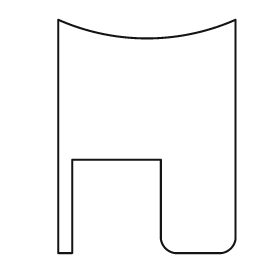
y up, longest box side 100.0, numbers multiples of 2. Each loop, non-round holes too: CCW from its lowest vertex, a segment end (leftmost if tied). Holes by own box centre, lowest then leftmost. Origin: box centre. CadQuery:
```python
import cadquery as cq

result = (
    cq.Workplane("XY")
    .moveTo(-38.0, -50.0)
    .lineTo(-32.0, -50.0)
    .lineTo(-32.0, -10.0)
    .lineTo(6.0, -10.0)
    .lineTo(6.0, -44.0)
    .threePointArc((8.0, -48.0), (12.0, -50.0))
    .lineTo(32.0, -50.0)
    .threePointArc((36.0, -48.0), (38.0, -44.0))
    .lineTo(38.0, 50.0)
    .threePointArc((0.0, 42.0), (-38.0, 50.0))
    .close()
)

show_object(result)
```